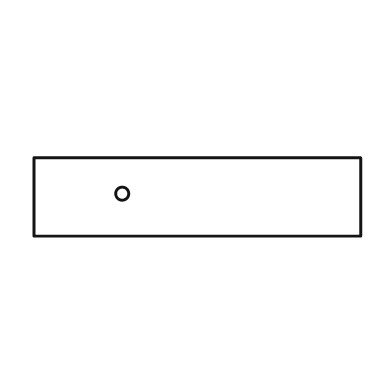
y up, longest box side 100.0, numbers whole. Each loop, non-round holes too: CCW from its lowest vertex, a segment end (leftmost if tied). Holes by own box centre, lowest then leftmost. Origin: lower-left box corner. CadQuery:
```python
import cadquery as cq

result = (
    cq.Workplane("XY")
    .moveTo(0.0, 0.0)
    .lineTo(100.0, 0.0)
    .lineTo(100.0, 24.0)
    .lineTo(0.0, 24.0)
    .close()
    .moveTo(27.0, 13.0)
    .circle(2.0)
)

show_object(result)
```